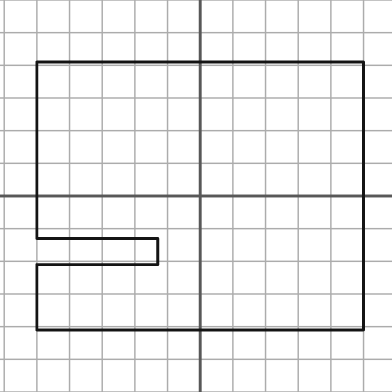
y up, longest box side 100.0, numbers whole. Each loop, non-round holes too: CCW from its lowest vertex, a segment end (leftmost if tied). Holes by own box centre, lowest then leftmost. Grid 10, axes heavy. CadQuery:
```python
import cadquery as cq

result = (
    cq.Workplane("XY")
    .moveTo(-50.0, -41.0)
    .lineTo(50.0, -41.0)
    .lineTo(50.0, 41.0)
    .lineTo(-50.0, 41.0)
    .lineTo(-50.0, -13.0)
    .lineTo(-13.0, -13.0)
    .lineTo(-13.0, -21.0)
    .lineTo(-50.0, -21.0)
    .close()
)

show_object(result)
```